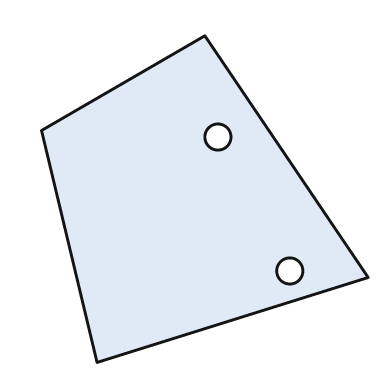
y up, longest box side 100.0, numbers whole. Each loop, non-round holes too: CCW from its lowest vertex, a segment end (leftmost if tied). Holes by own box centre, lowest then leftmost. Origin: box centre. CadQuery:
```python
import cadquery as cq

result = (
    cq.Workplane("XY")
    .moveTo(-33.0, -50.0)
    .lineTo(50.0, -24.0)
    .lineTo(0.0, 50.0)
    .lineTo(-50.0, 21.0)
    .close()
    .moveTo(26.0, -22.0)
    .circle(4.0)
    .moveTo(4.0, 19.0)
    .circle(4.0)
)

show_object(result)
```